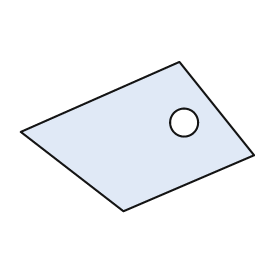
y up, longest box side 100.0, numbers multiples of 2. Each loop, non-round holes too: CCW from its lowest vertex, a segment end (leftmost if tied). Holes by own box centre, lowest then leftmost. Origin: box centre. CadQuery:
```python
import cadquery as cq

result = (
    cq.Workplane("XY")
    .moveTo(-6.0, -32.0)
    .lineTo(50.0, -8.0)
    .lineTo(18.0, 32.0)
    .lineTo(-50.0, 2.0)
    .close()
    .moveTo(20.0, 6.0)
    .circle(6.0)
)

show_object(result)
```